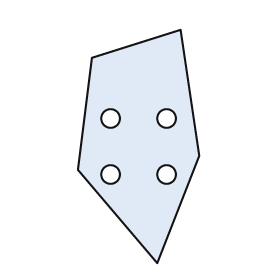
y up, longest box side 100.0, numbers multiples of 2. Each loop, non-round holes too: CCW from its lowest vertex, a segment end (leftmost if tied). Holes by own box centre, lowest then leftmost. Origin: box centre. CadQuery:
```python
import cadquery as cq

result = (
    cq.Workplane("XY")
    .moveTo(8.0, -50.0)
    .lineTo(26.0, -4.0)
    .lineTo(18.0, 50.0)
    .lineTo(-20.0, 38.0)
    .lineTo(-26.0, -10.0)
    .close()
    .moveTo(-12.0, -12.0)
    .circle(4.0)
    .moveTo(12.0, -12.0)
    .circle(4.0)
    .moveTo(-12.0, 12.0)
    .circle(4.0)
    .moveTo(12.0, 12.0)
    .circle(4.0)
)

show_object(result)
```